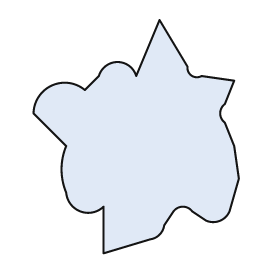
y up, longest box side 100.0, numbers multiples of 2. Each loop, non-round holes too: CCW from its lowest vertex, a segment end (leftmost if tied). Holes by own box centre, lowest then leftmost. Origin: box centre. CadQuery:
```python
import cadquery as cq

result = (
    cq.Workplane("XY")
    .moveTo(-14.0, -50.0)
    .lineTo(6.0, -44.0)
    .threePointArc((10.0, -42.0), (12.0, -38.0))
    .lineTo(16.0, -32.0)
    .threePointArc((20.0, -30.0), (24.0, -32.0))
    .lineTo(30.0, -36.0)
    .threePointArc((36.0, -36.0), (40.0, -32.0))
    .lineTo(44.0, -18.0)
    .lineTo(42.0, -4.0)
    .lineTo(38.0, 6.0)
    .threePointArc((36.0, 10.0), (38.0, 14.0))
    .lineTo(42.0, 24.0)
    .lineTo(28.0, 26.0)
    .threePointArc((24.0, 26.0), (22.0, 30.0))
    .lineTo(10.0, 50.0)
    .lineTo(0.0, 26.0)
    .threePointArc((-8.0, 32.0), (-16.0, 26.0))
    .lineTo(-22.0, 20.0)
    .threePointArc((-36.0, 22.0), (-44.0, 10.0))
    .lineTo(-30.0, -4.0)
    .threePointArc((-32.0, -14.0), (-30.0, -24.0))
    .threePointArc((-24.0, -32.0), (-14.0, -30.0))
    .close()
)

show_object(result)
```